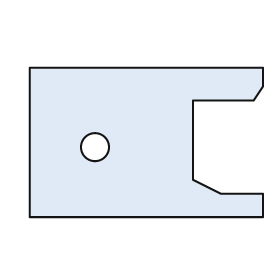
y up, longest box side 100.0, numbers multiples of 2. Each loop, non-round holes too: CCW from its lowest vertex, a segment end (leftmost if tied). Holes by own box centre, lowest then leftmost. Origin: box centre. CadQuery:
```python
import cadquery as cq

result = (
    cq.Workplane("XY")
    .moveTo(-50.0, -32.0)
    .lineTo(50.0, -32.0)
    .lineTo(50.0, -22.0)
    .lineTo(32.0, -22.0)
    .lineTo(20.0, -16.0)
    .lineTo(20.0, 18.0)
    .lineTo(46.0, 18.0)
    .lineTo(50.0, 24.0)
    .lineTo(50.0, 32.0)
    .lineTo(-50.0, 32.0)
    .close()
    .moveTo(-22.0, -2.0)
    .circle(6.0)
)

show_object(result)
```